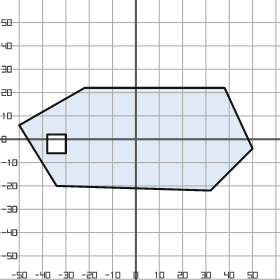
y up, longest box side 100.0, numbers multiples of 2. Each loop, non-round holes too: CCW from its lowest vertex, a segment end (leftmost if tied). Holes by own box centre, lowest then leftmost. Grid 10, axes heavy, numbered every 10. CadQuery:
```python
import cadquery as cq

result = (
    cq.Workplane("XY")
    .moveTo(32.0, -22.0)
    .lineTo(50.0, -4.0)
    .lineTo(38.0, 22.0)
    .lineTo(-22.0, 22.0)
    .lineTo(-50.0, 6.0)
    .lineTo(-34.0, -20.0)
    .close()
    .moveTo(-38.0, -6.0)
    .lineTo(-30.0, -6.0)
    .lineTo(-30.0, 2.0)
    .lineTo(-38.0, 2.0)
    .close()
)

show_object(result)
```